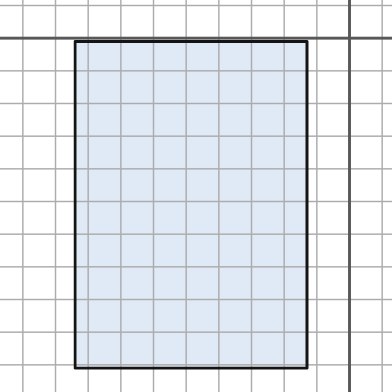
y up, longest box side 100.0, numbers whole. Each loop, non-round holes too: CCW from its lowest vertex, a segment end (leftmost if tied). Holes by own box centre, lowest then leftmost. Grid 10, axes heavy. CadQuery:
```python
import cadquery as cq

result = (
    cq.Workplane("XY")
    .moveTo(-84.0, -101.0)
    .lineTo(-13.0, -101.0)
    .lineTo(-13.0, -1.0)
    .lineTo(-84.0, -1.0)
    .close()
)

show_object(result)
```